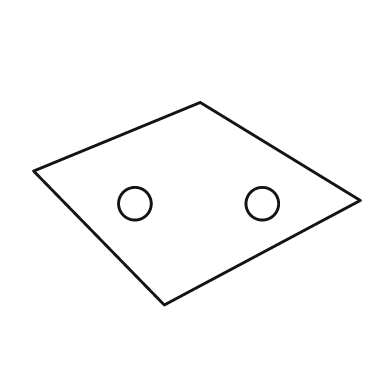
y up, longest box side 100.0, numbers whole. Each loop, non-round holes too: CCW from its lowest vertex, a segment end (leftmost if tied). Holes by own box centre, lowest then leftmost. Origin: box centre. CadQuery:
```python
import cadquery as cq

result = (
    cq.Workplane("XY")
    .moveTo(-10.0, -31.0)
    .lineTo(50.0, 1.0)
    .lineTo(1.0, 31.0)
    .lineTo(-50.0, 10.0)
    .close()
    .moveTo(-19.0, 0.0)
    .circle(5.0)
    .moveTo(20.0, 0.0)
    .circle(5.0)
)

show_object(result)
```